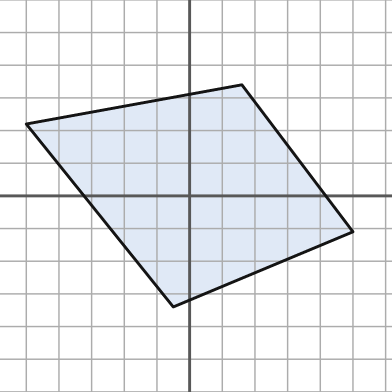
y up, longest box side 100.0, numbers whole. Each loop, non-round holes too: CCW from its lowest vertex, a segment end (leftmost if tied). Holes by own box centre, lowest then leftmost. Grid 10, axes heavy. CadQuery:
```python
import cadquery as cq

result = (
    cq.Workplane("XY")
    .moveTo(-5.0, -34.0)
    .lineTo(50.0, -11.0)
    .lineTo(16.0, 34.0)
    .lineTo(-50.0, 22.0)
    .close()
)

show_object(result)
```